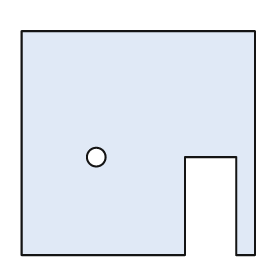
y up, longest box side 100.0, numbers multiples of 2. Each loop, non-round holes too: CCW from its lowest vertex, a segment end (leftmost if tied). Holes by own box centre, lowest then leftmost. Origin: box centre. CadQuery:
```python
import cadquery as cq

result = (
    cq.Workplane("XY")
    .moveTo(-50.0, -48.0)
    .lineTo(20.0, -48.0)
    .lineTo(20.0, -6.0)
    .lineTo(42.0, -6.0)
    .lineTo(42.0, -48.0)
    .lineTo(50.0, -48.0)
    .lineTo(50.0, 48.0)
    .lineTo(-50.0, 48.0)
    .close()
    .moveTo(-18.0, -6.0)
    .circle(4.0)
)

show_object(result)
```